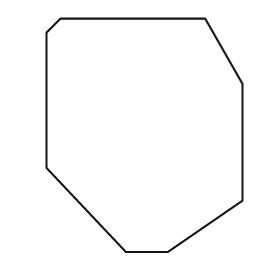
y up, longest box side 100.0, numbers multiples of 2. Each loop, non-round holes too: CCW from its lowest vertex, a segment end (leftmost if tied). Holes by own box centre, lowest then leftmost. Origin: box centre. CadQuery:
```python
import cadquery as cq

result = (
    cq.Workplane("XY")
    .moveTo(-8.0, -50.0)
    .lineTo(10.0, -50.0)
    .lineTo(42.0, -28.0)
    .lineTo(42.0, 22.0)
    .lineTo(26.0, 50.0)
    .lineTo(-36.0, 50.0)
    .lineTo(-42.0, 44.0)
    .lineTo(-42.0, -14.0)
    .close()
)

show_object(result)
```